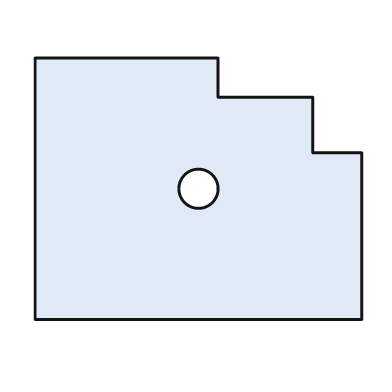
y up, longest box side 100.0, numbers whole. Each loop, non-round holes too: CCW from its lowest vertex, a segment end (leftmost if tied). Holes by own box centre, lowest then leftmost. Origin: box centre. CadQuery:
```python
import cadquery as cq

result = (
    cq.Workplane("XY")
    .moveTo(-50.0, -40.0)
    .lineTo(50.0, -40.0)
    .lineTo(50.0, 11.0)
    .lineTo(35.0, 11.0)
    .lineTo(35.0, 28.0)
    .lineTo(6.0, 28.0)
    .lineTo(6.0, 40.0)
    .lineTo(-50.0, 40.0)
    .close()
    .moveTo(0.0, 0.0)
    .circle(6.0)
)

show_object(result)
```